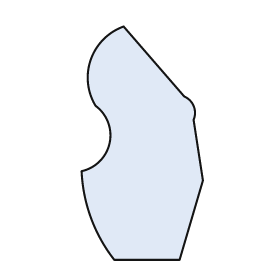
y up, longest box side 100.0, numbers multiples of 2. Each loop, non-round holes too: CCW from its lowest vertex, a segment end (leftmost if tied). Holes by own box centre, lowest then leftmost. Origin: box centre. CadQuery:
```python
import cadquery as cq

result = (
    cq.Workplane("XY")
    .moveTo(-12.0, -50.0)
    .lineTo(16.0, -50.0)
    .lineTo(26.0, -16.0)
    .lineTo(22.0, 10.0)
    .threePointArc((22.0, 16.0), (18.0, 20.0))
    .lineTo(-8.0, 50.0)
    .threePointArc((-22.0, 36.0), (-20.0, 16.0))
    .threePointArc((-14.0, 0.0), (-26.0, -12.0))
    .threePointArc((-22.0, -32.0), (-12.0, -50.0))
    .close()
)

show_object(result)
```